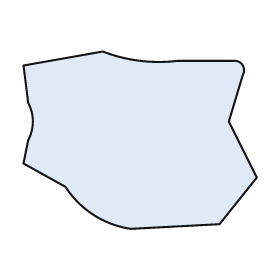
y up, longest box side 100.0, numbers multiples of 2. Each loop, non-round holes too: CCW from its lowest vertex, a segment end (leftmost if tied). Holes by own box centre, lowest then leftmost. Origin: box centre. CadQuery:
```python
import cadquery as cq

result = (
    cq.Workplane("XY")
    .moveTo(-4.0, -38.0)
    .lineTo(34.0, -36.0)
    .lineTo(50.0, -16.0)
    .lineTo(38.0, 8.0)
    .lineTo(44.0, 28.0)
    .threePointArc((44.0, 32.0), (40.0, 34.0))
    .lineTo(16.0, 34.0)
    .threePointArc((0.0, 34.0), (-16.0, 38.0))
    .lineTo(-50.0, 32.0)
    .lineTo(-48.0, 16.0)
    .threePointArc((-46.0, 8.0), (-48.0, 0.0))
    .lineTo(-50.0, -10.0)
    .lineTo(-32.0, -20.0)
    .threePointArc((-20.0, -32.0), (-4.0, -38.0))
    .close()
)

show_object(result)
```